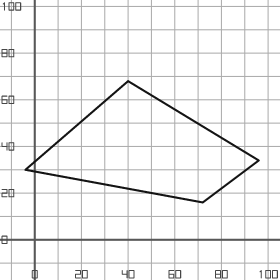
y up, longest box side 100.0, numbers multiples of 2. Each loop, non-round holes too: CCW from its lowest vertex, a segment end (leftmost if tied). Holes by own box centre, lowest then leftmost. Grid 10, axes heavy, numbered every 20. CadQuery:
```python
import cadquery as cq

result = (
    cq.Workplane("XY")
    .moveTo(72.0, 16.0)
    .lineTo(96.0, 34.0)
    .lineTo(40.0, 68.0)
    .lineTo(-4.0, 30.0)
    .close()
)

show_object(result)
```